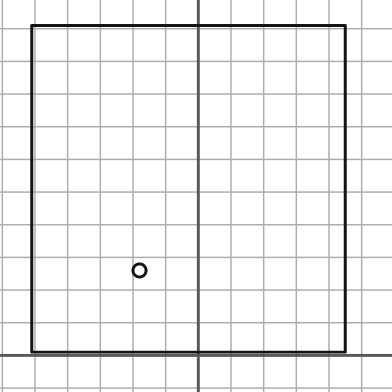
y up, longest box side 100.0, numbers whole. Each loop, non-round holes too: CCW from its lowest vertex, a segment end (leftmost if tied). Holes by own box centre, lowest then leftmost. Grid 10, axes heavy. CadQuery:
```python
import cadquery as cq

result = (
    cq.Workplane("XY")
    .moveTo(-51.0, 1.0)
    .lineTo(45.0, 1.0)
    .lineTo(45.0, 101.0)
    .lineTo(-51.0, 101.0)
    .close()
    .moveTo(-18.0, 26.0)
    .circle(2.0)
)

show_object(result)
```